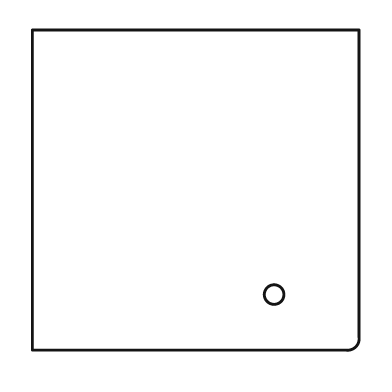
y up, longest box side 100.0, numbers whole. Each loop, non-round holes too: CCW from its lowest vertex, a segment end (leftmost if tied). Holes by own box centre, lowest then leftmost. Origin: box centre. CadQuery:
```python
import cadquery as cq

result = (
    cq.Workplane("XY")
    .moveTo(-50.0, -49.0)
    .lineTo(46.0, -49.0)
    .threePointArc((49.0, -48.0), (50.0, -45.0))
    .lineTo(50.0, 49.0)
    .lineTo(-50.0, 49.0)
    .close()
    .moveTo(24.0, -32.0)
    .circle(3.0)
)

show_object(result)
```